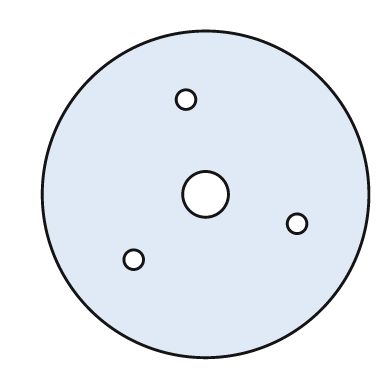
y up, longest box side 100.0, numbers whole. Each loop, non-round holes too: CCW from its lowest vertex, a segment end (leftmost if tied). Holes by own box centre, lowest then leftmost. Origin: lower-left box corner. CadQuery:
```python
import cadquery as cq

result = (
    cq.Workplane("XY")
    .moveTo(50.0, 50.0)
    .circle(50.0)
    .moveTo(28.0, 30.0)
    .circle(3.0)
    .moveTo(78.0, 41.0)
    .circle(3.0)
    .moveTo(50.0, 50.0)
    .circle(7.0)
    .moveTo(44.0, 79.0)
    .circle(3.0)
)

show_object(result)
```